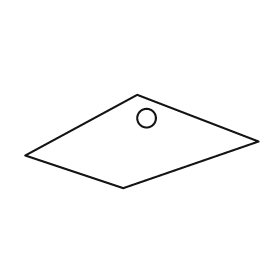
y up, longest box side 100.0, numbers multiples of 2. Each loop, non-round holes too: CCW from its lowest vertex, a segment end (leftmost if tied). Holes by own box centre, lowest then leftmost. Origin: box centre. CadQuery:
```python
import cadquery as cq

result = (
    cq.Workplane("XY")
    .moveTo(-8.0, -20.0)
    .lineTo(50.0, 0.0)
    .lineTo(-2.0, 20.0)
    .lineTo(-50.0, -6.0)
    .close()
    .moveTo(2.0, 10.0)
    .circle(4.0)
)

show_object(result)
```